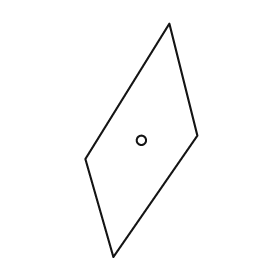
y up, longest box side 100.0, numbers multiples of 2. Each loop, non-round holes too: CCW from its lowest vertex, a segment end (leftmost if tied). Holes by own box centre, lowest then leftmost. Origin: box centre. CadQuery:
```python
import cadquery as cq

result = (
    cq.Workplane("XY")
    .moveTo(-12.0, -50.0)
    .lineTo(24.0, 2.0)
    .lineTo(12.0, 50.0)
    .lineTo(-24.0, -8.0)
    .close()
    .moveTo(0.0, 0.0)
    .circle(2.0)
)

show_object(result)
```